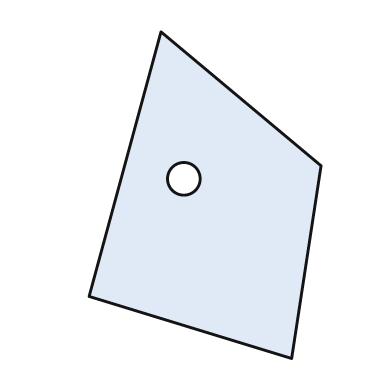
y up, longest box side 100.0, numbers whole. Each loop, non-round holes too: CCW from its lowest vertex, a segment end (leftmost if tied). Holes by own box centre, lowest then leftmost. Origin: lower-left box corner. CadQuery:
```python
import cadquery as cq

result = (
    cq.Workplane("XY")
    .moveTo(62.0, 0.0)
    .lineTo(71.0, 59.0)
    .lineTo(22.0, 100.0)
    .lineTo(0.0, 19.0)
    .close()
    .moveTo(29.0, 55.0)
    .circle(5.0)
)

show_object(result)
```